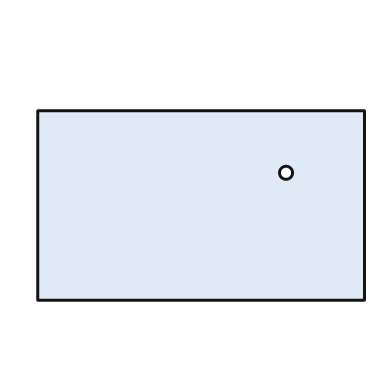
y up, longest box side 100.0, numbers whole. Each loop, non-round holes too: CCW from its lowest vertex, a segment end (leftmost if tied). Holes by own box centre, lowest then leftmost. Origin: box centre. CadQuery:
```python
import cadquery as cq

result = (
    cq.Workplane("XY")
    .moveTo(-50.0, -29.0)
    .lineTo(50.0, -29.0)
    .lineTo(50.0, 29.0)
    .lineTo(-50.0, 29.0)
    .close()
    .moveTo(26.0, 10.0)
    .circle(2.0)
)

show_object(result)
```